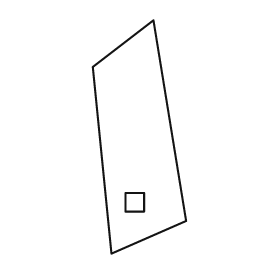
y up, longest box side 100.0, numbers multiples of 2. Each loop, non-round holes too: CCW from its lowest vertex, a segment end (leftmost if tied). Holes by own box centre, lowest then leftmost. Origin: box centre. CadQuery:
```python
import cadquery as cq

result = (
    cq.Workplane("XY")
    .moveTo(-12.0, -50.0)
    .lineTo(20.0, -36.0)
    .lineTo(6.0, 50.0)
    .lineTo(-20.0, 30.0)
    .close()
    .moveTo(-6.0, -32.0)
    .lineTo(2.0, -32.0)
    .lineTo(2.0, -24.0)
    .lineTo(-6.0, -24.0)
    .close()
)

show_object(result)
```